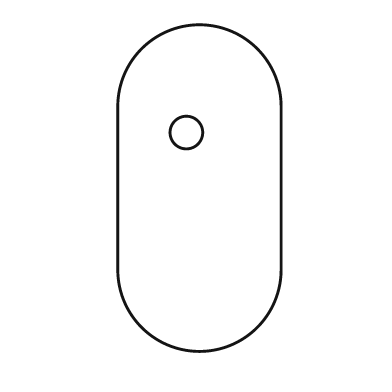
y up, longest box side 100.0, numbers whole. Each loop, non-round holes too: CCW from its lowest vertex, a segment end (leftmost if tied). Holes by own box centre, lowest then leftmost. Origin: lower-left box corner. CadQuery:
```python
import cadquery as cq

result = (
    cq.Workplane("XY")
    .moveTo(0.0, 25.0)
    .threePointArc((25.0, 0.0), (50.0, 25.0))
    .lineTo(50.0, 75.0)
    .threePointArc((25.0, 100.0), (0.0, 75.0))
    .close()
    .moveTo(21.0, 67.0)
    .circle(5.0)
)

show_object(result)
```